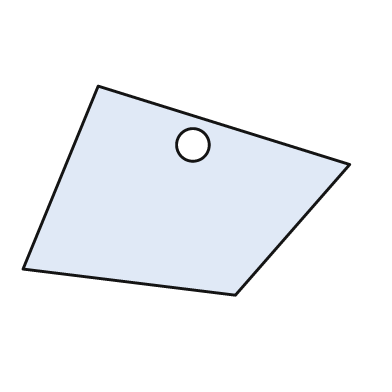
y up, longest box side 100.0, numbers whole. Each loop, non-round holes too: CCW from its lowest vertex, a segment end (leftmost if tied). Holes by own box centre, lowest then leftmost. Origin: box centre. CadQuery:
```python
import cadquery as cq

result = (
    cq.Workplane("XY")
    .moveTo(15.0, -32.0)
    .lineTo(50.0, 8.0)
    .lineTo(-27.0, 32.0)
    .lineTo(-50.0, -24.0)
    .close()
    .moveTo(2.0, 14.0)
    .circle(5.0)
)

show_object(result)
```